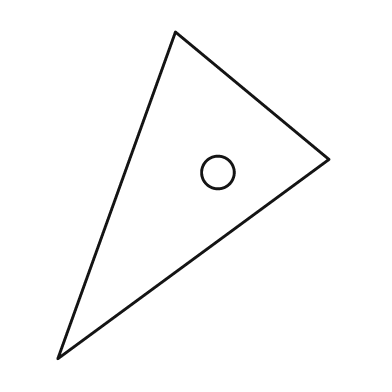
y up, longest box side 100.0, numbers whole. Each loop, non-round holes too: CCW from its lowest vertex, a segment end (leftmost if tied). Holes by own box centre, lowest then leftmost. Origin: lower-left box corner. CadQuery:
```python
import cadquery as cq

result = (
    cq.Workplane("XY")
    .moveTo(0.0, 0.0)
    .lineTo(83.0, 61.0)
    .lineTo(36.0, 100.0)
    .close()
    .moveTo(49.0, 57.0)
    .circle(5.0)
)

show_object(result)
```